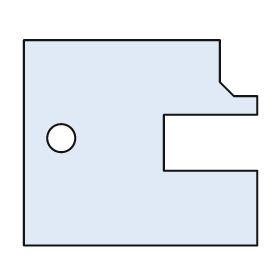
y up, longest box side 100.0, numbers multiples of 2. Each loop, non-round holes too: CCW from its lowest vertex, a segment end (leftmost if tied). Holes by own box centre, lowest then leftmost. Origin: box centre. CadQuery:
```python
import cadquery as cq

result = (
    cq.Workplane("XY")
    .moveTo(-50.0, -44.0)
    .lineTo(50.0, -44.0)
    .lineTo(50.0, -12.0)
    .lineTo(10.0, -12.0)
    .lineTo(10.0, 12.0)
    .lineTo(50.0, 12.0)
    .lineTo(50.0, 20.0)
    .lineTo(40.0, 20.0)
    .lineTo(34.0, 26.0)
    .lineTo(34.0, 44.0)
    .lineTo(-50.0, 44.0)
    .close()
    .moveTo(-34.0, 2.0)
    .circle(6.0)
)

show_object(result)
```